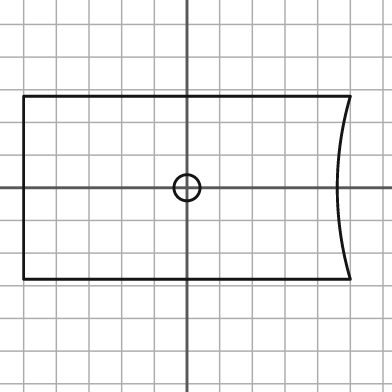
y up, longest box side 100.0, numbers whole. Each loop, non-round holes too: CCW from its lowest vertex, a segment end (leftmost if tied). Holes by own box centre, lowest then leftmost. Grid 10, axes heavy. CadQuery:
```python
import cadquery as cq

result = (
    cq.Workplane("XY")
    .moveTo(-50.0, -28.0)
    .lineTo(50.0, -28.0)
    .threePointArc((46.0, 0.0), (50.0, 28.0))
    .lineTo(-50.0, 28.0)
    .close()
    .moveTo(0.0, 0.0)
    .circle(4.0)
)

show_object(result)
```